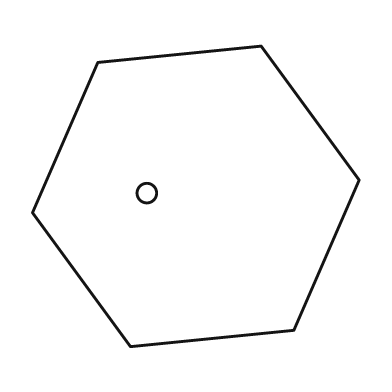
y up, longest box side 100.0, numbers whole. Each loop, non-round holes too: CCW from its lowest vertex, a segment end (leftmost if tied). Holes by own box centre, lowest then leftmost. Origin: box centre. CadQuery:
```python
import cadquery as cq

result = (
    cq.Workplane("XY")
    .moveTo(-20.0, -46.0)
    .lineTo(30.0, -41.0)
    .lineTo(50.0, 5.0)
    .lineTo(20.0, 46.0)
    .lineTo(-30.0, 41.0)
    .lineTo(-50.0, -5.0)
    .close()
    .moveTo(-15.0, 1.0)
    .circle(3.0)
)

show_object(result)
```